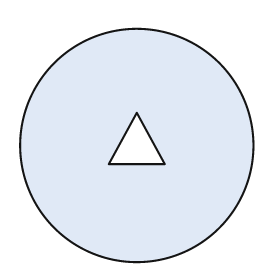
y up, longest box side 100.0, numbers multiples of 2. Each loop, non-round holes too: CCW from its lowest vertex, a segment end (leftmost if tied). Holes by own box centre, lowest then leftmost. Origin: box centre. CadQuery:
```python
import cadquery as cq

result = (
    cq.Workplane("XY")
    .moveTo(0.0, 0.0)
    .circle(50.0)
    .moveTo(-12.0, -8.0)
    .lineTo(12.0, -8.0)
    .lineTo(0.0, 14.0)
    .close()
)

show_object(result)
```